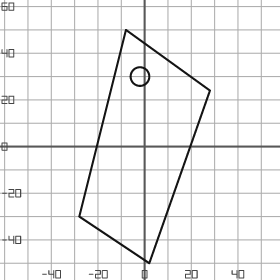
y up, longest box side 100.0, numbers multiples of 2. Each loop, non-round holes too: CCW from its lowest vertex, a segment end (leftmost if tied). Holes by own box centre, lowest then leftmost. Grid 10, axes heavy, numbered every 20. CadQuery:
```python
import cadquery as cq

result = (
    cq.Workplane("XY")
    .moveTo(2.0, -50.0)
    .lineTo(28.0, 24.0)
    .lineTo(-8.0, 50.0)
    .lineTo(-28.0, -30.0)
    .close()
    .moveTo(-2.0, 30.0)
    .circle(4.0)
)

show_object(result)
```